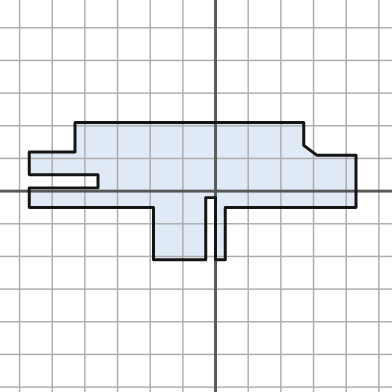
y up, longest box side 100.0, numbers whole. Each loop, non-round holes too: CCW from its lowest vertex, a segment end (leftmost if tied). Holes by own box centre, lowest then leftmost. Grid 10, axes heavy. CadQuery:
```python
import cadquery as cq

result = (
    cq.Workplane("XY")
    .moveTo(-19.0, -21.0)
    .lineTo(-3.0, -21.0)
    .lineTo(-3.0, -2.0)
    .lineTo(0.0, -2.0)
    .lineTo(0.0, -21.0)
    .lineTo(3.0, -21.0)
    .lineTo(3.0, -5.0)
    .lineTo(43.0, -5.0)
    .lineTo(43.0, 11.0)
    .lineTo(31.0, 11.0)
    .lineTo(27.0, 14.0)
    .lineTo(27.0, 21.0)
    .lineTo(-43.0, 21.0)
    .lineTo(-43.0, 12.0)
    .lineTo(-57.0, 12.0)
    .lineTo(-57.0, 5.0)
    .lineTo(-36.0, 5.0)
    .lineTo(-36.0, 1.0)
    .lineTo(-57.0, 1.0)
    .lineTo(-57.0, -5.0)
    .lineTo(-19.0, -5.0)
    .close()
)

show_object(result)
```